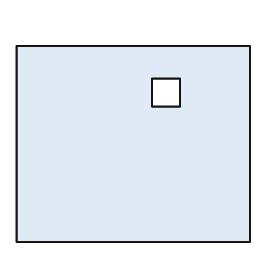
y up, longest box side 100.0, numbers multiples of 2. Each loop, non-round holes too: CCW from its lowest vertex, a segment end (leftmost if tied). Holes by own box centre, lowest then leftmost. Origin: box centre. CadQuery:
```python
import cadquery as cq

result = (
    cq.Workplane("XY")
    .moveTo(-50.0, -42.0)
    .lineTo(50.0, -42.0)
    .lineTo(50.0, 42.0)
    .lineTo(-50.0, 42.0)
    .close()
    .moveTo(8.0, 16.0)
    .lineTo(20.0, 16.0)
    .lineTo(20.0, 28.0)
    .lineTo(8.0, 28.0)
    .close()
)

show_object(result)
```